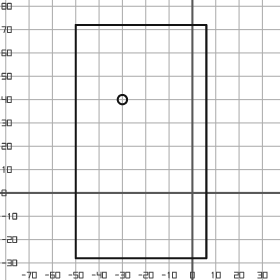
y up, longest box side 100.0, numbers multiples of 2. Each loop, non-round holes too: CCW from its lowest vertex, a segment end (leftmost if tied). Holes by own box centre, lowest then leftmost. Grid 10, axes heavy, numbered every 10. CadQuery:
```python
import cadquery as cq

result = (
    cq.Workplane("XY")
    .moveTo(-50.0, -28.0)
    .lineTo(6.0, -28.0)
    .lineTo(6.0, 72.0)
    .lineTo(-50.0, 72.0)
    .close()
    .moveTo(-30.0, 40.0)
    .circle(2.0)
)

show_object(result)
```